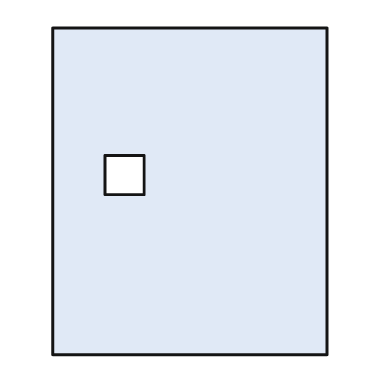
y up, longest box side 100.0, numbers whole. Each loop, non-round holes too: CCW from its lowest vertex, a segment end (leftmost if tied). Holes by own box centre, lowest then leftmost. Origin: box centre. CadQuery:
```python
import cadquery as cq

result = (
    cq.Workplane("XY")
    .moveTo(-42.0, -50.0)
    .lineTo(42.0, -50.0)
    .lineTo(42.0, 50.0)
    .lineTo(-42.0, 50.0)
    .close()
    .moveTo(-26.0, -1.0)
    .lineTo(-14.0, -1.0)
    .lineTo(-14.0, 11.0)
    .lineTo(-26.0, 11.0)
    .close()
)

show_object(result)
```